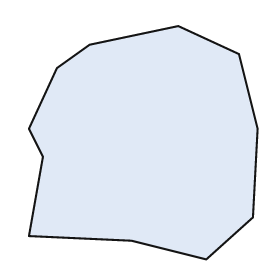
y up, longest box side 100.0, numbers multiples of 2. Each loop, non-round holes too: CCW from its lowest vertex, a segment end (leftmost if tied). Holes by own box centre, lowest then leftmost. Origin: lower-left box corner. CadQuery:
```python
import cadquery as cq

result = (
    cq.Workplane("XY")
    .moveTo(76.0, 0.0)
    .lineTo(96.0, 18.0)
    .lineTo(98.0, 56.0)
    .lineTo(90.0, 88.0)
    .lineTo(64.0, 100.0)
    .lineTo(26.0, 92.0)
    .lineTo(12.0, 82.0)
    .lineTo(0.0, 56.0)
    .lineTo(6.0, 44.0)
    .lineTo(0.0, 10.0)
    .lineTo(44.0, 8.0)
    .close()
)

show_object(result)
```